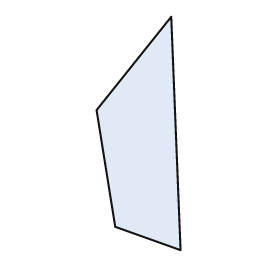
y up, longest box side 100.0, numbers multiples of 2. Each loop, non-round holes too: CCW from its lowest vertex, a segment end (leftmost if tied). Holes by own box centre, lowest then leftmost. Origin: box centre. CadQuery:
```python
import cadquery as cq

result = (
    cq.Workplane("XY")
    .moveTo(18.0, -50.0)
    .lineTo(14.0, 50.0)
    .lineTo(-18.0, 10.0)
    .lineTo(-10.0, -40.0)
    .close()
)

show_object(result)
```